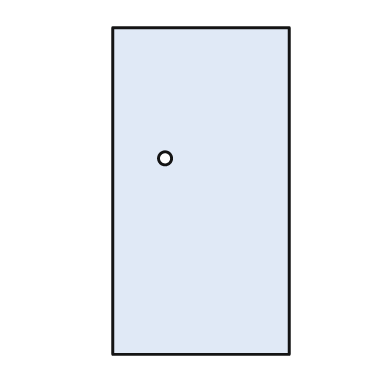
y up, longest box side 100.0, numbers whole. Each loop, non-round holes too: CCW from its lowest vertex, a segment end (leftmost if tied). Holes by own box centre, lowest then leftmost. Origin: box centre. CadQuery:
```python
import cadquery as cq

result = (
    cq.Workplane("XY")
    .moveTo(-27.0, -50.0)
    .lineTo(27.0, -50.0)
    .lineTo(27.0, 50.0)
    .lineTo(-27.0, 50.0)
    .close()
    .moveTo(-11.0, 10.0)
    .circle(2.0)
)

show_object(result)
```